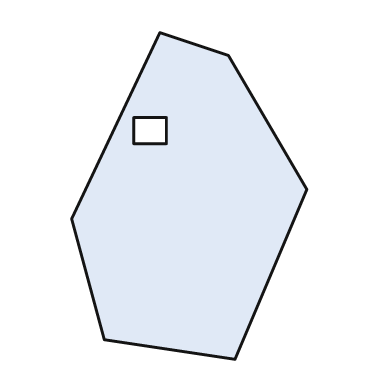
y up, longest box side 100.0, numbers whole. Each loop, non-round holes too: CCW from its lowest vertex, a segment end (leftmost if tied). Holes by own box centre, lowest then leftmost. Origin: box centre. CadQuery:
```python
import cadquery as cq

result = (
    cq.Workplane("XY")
    .moveTo(14.0, -50.0)
    .lineTo(36.0, 2.0)
    .lineTo(12.0, 43.0)
    .lineTo(-9.0, 50.0)
    .lineTo(-36.0, -7.0)
    .lineTo(-26.0, -44.0)
    .close()
    .moveTo(-17.0, 16.0)
    .lineTo(-7.0, 16.0)
    .lineTo(-7.0, 24.0)
    .lineTo(-17.0, 24.0)
    .close()
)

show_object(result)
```